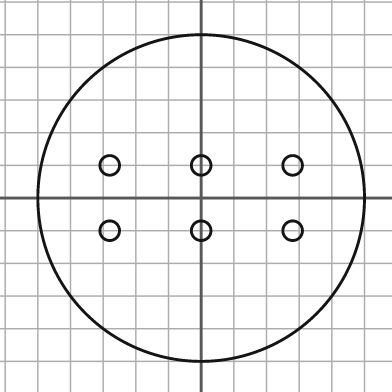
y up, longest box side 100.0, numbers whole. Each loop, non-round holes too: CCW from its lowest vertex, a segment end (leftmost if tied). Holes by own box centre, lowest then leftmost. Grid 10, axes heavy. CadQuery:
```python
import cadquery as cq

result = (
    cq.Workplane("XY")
    .moveTo(0.0, 0.0)
    .circle(50.0)
    .moveTo(-28.0, -10.0)
    .circle(3.0)
    .moveTo(0.0, -10.0)
    .circle(3.0)
    .moveTo(28.0, -10.0)
    .circle(3.0)
    .moveTo(-28.0, 10.0)
    .circle(3.0)
    .moveTo(0.0, 10.0)
    .circle(3.0)
    .moveTo(28.0, 10.0)
    .circle(3.0)
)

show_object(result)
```